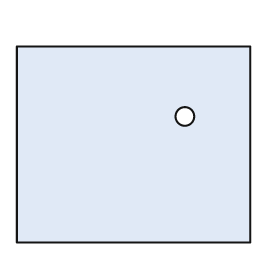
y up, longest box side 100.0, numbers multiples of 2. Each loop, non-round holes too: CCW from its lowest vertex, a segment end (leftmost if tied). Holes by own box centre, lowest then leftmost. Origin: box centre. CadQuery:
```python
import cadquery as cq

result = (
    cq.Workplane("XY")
    .moveTo(-50.0, -42.0)
    .lineTo(50.0, -42.0)
    .lineTo(50.0, 42.0)
    .lineTo(-50.0, 42.0)
    .close()
    .moveTo(22.0, 12.0)
    .circle(4.0)
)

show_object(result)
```